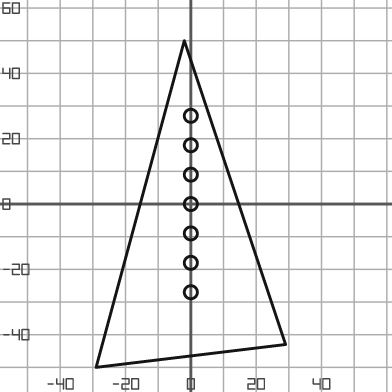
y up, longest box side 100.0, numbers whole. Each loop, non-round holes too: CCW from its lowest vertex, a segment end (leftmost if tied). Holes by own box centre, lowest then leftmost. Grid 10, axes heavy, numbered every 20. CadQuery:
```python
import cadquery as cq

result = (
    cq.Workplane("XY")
    .moveTo(-29.0, -50.0)
    .lineTo(29.0, -43.0)
    .lineTo(-2.0, 50.0)
    .close()
    .moveTo(0.0, -27.0)
    .circle(2.0)
    .moveTo(0.0, -18.0)
    .circle(2.0)
    .moveTo(0.0, -9.0)
    .circle(2.0)
    .moveTo(0.0, 0.0)
    .circle(2.0)
    .moveTo(0.0, 9.0)
    .circle(2.0)
    .moveTo(0.0, 18.0)
    .circle(2.0)
    .moveTo(0.0, 27.0)
    .circle(2.0)
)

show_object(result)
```